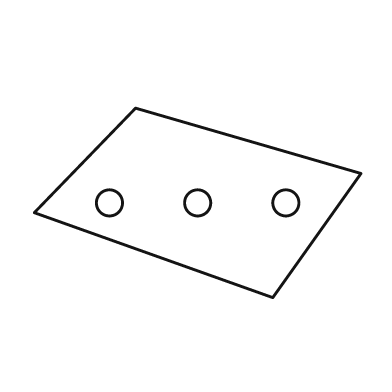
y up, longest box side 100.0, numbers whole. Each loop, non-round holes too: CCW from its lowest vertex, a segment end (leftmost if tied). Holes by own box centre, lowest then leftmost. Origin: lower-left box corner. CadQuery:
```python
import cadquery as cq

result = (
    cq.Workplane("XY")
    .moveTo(73.0, 0.0)
    .lineTo(100.0, 38.0)
    .lineTo(31.0, 58.0)
    .lineTo(0.0, 26.0)
    .close()
    .moveTo(23.0, 29.0)
    .circle(4.0)
    .moveTo(50.0, 29.0)
    .circle(4.0)
    .moveTo(77.0, 29.0)
    .circle(4.0)
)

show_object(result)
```